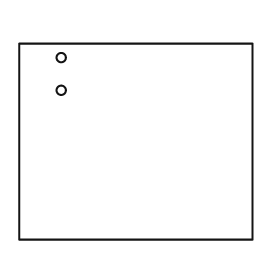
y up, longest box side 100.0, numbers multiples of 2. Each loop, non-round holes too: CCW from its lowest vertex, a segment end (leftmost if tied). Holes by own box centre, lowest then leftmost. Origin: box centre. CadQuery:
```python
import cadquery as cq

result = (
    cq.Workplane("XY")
    .moveTo(-50.0, -42.0)
    .lineTo(50.0, -42.0)
    .lineTo(50.0, 42.0)
    .lineTo(-50.0, 42.0)
    .close()
    .moveTo(-32.0, 22.0)
    .circle(2.0)
    .moveTo(-32.0, 36.0)
    .circle(2.0)
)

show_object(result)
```